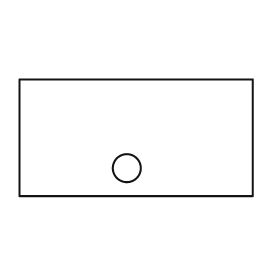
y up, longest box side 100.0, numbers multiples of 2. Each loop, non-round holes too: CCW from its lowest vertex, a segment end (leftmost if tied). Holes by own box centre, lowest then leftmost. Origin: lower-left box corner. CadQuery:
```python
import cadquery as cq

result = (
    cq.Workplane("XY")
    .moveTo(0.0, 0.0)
    .lineTo(100.0, 0.0)
    .lineTo(100.0, 50.0)
    .lineTo(0.0, 50.0)
    .close()
    .moveTo(46.0, 12.0)
    .circle(6.0)
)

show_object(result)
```